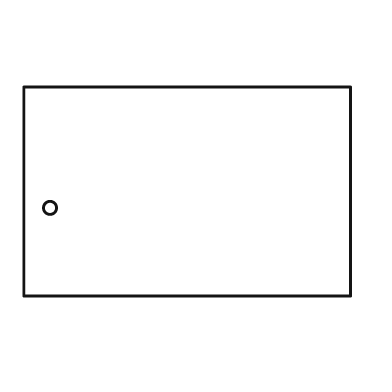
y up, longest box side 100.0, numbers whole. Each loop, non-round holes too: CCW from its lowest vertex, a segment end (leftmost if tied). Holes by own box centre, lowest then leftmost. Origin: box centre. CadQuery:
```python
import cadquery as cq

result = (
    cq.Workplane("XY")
    .moveTo(-50.0, -32.0)
    .lineTo(50.0, -32.0)
    .lineTo(50.0, 32.0)
    .lineTo(-50.0, 32.0)
    .close()
    .moveTo(-42.0, -5.0)
    .circle(2.0)
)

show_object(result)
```